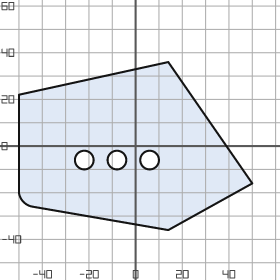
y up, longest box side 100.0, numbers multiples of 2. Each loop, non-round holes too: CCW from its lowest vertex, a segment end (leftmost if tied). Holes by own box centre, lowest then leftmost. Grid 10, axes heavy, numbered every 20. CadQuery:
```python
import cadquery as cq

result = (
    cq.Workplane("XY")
    .moveTo(14.0, -36.0)
    .lineTo(50.0, -16.0)
    .lineTo(14.0, 36.0)
    .lineTo(-50.0, 22.0)
    .lineTo(-50.0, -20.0)
    .threePointArc((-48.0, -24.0), (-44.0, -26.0))
    .close()
    .moveTo(-22.0, -6.0)
    .circle(4.0)
    .moveTo(-8.0, -6.0)
    .circle(4.0)
    .moveTo(6.0, -6.0)
    .circle(4.0)
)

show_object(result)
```